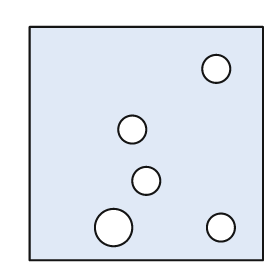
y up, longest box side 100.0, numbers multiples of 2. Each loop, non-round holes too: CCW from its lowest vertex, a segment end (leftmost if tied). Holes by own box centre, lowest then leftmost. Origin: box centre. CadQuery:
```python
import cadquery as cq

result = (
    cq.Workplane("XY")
    .moveTo(-50.0, -50.0)
    .lineTo(50.0, -50.0)
    .lineTo(50.0, 50.0)
    .lineTo(-50.0, 50.0)
    .close()
    .moveTo(-14.0, -36.0)
    .circle(8.0)
    .moveTo(32.0, -36.0)
    .circle(6.0)
    .moveTo(0.0, -16.0)
    .circle(6.0)
    .moveTo(-6.0, 6.0)
    .circle(6.0)
    .moveTo(30.0, 32.0)
    .circle(6.0)
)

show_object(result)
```